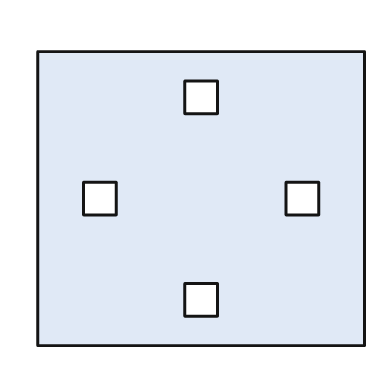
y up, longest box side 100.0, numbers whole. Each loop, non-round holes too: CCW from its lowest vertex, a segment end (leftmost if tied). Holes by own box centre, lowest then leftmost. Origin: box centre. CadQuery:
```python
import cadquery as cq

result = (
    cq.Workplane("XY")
    .moveTo(-50.0, -45.0)
    .lineTo(50.0, -45.0)
    .lineTo(50.0, 45.0)
    .lineTo(-50.0, 45.0)
    .close()
    .moveTo(-5.0, -36.0)
    .lineTo(5.0, -36.0)
    .lineTo(5.0, -26.0)
    .lineTo(-5.0, -26.0)
    .close()
    .moveTo(-36.0, -5.0)
    .lineTo(-26.0, -5.0)
    .lineTo(-26.0, 5.0)
    .lineTo(-36.0, 5.0)
    .close()
    .moveTo(26.0, -5.0)
    .lineTo(36.0, -5.0)
    .lineTo(36.0, 5.0)
    .lineTo(26.0, 5.0)
    .close()
    .moveTo(-5.0, 26.0)
    .lineTo(5.0, 26.0)
    .lineTo(5.0, 36.0)
    .lineTo(-5.0, 36.0)
    .close()
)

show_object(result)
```